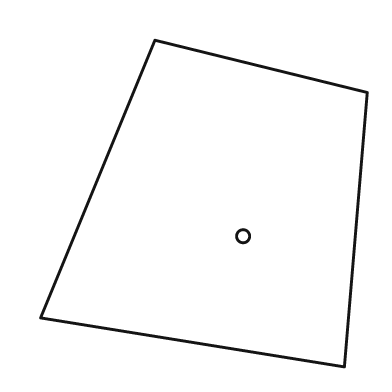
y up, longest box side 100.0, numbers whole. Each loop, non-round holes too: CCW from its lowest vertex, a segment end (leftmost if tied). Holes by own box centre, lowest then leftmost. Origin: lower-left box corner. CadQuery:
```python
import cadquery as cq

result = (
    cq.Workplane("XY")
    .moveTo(93.0, 0.0)
    .lineTo(100.0, 84.0)
    .lineTo(35.0, 100.0)
    .lineTo(0.0, 15.0)
    .close()
    .moveTo(62.0, 40.0)
    .circle(2.0)
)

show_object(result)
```